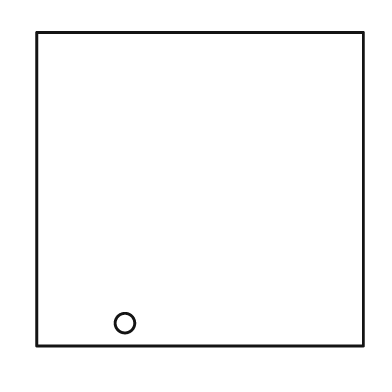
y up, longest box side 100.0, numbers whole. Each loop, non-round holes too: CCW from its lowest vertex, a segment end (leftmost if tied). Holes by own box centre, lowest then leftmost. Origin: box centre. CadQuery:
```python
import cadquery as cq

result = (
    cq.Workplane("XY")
    .moveTo(-50.0, -48.0)
    .lineTo(50.0, -48.0)
    .lineTo(50.0, 48.0)
    .lineTo(-50.0, 48.0)
    .close()
    .moveTo(-23.0, -41.0)
    .circle(3.0)
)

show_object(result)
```